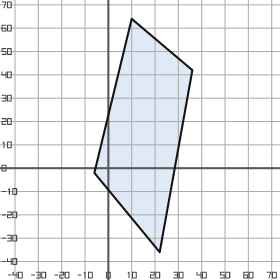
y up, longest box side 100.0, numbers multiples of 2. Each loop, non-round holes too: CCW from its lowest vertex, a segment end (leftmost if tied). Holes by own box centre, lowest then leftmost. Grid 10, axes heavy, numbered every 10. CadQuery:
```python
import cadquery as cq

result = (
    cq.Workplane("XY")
    .moveTo(22.0, -36.0)
    .lineTo(36.0, 42.0)
    .lineTo(10.0, 64.0)
    .lineTo(-6.0, -2.0)
    .close()
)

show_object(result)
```